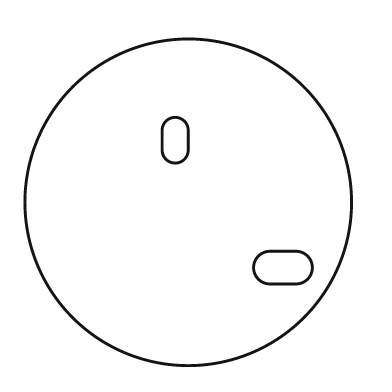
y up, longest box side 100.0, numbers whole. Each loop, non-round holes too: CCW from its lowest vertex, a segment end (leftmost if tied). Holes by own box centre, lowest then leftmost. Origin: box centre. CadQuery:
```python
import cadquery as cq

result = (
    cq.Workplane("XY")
    .moveTo(0.0, 0.0)
    .circle(50.0)
    .moveTo(25.0, -25.0)
    .lineTo(33.0, -25.0)
    .threePointArc((38.0, -20.0), (33.0, -15.0))
    .lineTo(25.0, -15.0)
    .threePointArc((20.0, -20.0), (25.0, -25.0))
    .close()
    .moveTo(-8.0, 16.0)
    .threePointArc((-4.0, 12.0), (0.0, 16.0))
    .lineTo(0.0, 22.0)
    .threePointArc((-4.0, 26.0), (-8.0, 22.0))
    .close()
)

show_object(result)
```